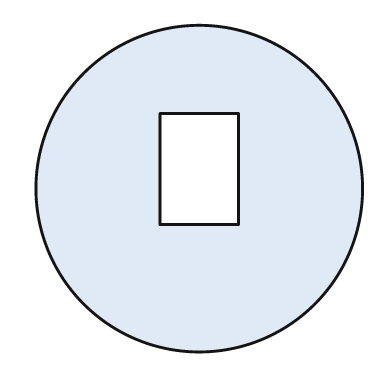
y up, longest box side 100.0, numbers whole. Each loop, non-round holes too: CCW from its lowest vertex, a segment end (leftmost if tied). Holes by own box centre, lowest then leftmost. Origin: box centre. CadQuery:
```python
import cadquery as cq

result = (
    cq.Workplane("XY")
    .moveTo(0.0, 0.0)
    .circle(50.0)
    .moveTo(-12.0, -11.0)
    .lineTo(12.0, -11.0)
    .lineTo(12.0, 23.0)
    .lineTo(-12.0, 23.0)
    .close()
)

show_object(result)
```